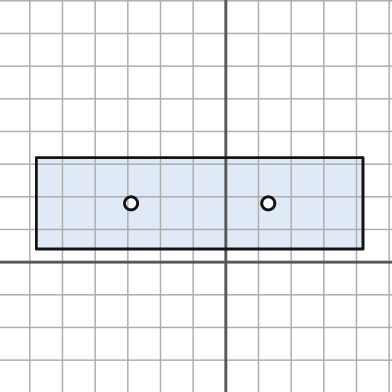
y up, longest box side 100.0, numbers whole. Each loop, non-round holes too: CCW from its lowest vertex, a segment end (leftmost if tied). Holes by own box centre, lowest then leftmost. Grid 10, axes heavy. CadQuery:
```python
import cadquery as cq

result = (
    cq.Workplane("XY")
    .moveTo(-58.0, 4.0)
    .lineTo(42.0, 4.0)
    .lineTo(42.0, 32.0)
    .lineTo(-58.0, 32.0)
    .close()
    .moveTo(-29.0, 18.0)
    .circle(2.0)
    .moveTo(13.0, 18.0)
    .circle(2.0)
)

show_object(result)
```